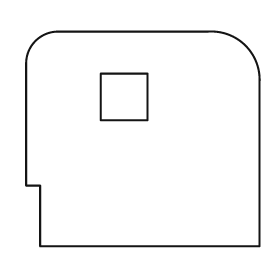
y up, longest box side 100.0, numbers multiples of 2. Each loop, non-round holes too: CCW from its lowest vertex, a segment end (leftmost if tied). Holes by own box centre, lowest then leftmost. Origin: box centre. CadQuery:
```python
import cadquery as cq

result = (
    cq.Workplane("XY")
    .moveTo(-44.0, -46.0)
    .lineTo(50.0, -46.0)
    .lineTo(50.0, 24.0)
    .threePointArc((44.0, 40.0), (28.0, 46.0))
    .lineTo(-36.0, 46.0)
    .threePointArc((-46.0, 42.0), (-50.0, 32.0))
    .lineTo(-50.0, -20.0)
    .lineTo(-44.0, -20.0)
    .close()
    .moveTo(-18.0, 8.0)
    .lineTo(2.0, 8.0)
    .lineTo(2.0, 28.0)
    .lineTo(-18.0, 28.0)
    .close()
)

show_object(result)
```